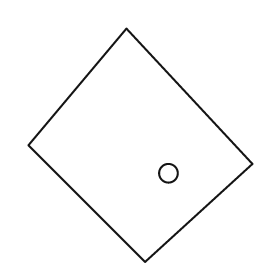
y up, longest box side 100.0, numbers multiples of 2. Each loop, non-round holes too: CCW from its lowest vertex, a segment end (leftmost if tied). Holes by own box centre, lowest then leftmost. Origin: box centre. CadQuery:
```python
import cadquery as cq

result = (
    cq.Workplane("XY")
    .moveTo(2.0, -50.0)
    .lineTo(48.0, -8.0)
    .lineTo(-6.0, 50.0)
    .lineTo(-48.0, 0.0)
    .close()
    .moveTo(12.0, -12.0)
    .circle(4.0)
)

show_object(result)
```